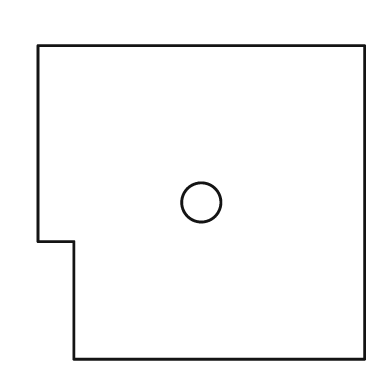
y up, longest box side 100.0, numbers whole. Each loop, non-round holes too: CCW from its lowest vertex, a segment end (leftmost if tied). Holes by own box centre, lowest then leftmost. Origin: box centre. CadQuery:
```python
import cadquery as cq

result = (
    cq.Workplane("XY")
    .moveTo(-39.0, -48.0)
    .lineTo(50.0, -48.0)
    .lineTo(50.0, 48.0)
    .lineTo(-50.0, 48.0)
    .lineTo(-50.0, -12.0)
    .lineTo(-39.0, -12.0)
    .close()
    .moveTo(0.0, 0.0)
    .circle(6.0)
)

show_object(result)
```